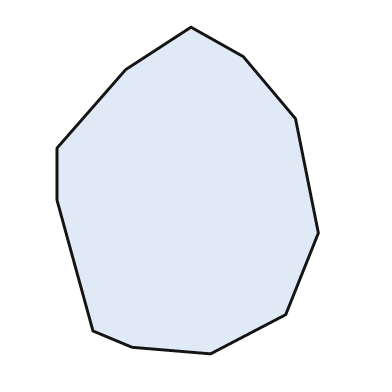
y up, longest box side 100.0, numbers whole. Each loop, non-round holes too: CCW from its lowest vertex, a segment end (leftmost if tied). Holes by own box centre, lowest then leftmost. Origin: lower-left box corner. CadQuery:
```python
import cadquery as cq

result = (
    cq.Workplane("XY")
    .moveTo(47.0, 0.0)
    .lineTo(70.0, 12.0)
    .lineTo(80.0, 37.0)
    .lineTo(73.0, 72.0)
    .lineTo(57.0, 91.0)
    .lineTo(41.0, 100.0)
    .lineTo(21.0, 87.0)
    .lineTo(0.0, 63.0)
    .lineTo(0.0, 47.0)
    .lineTo(11.0, 7.0)
    .lineTo(23.0, 2.0)
    .close()
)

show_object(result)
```